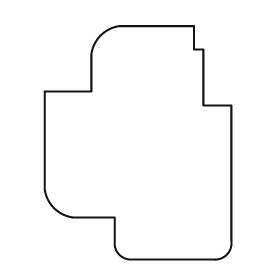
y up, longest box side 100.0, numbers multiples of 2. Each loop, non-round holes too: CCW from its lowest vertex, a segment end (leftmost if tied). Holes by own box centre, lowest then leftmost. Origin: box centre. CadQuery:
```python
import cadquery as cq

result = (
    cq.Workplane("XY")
    .moveTo(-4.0, -50.0)
    .lineTo(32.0, -50.0)
    .threePointArc((38.0, -48.0), (40.0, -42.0))
    .lineTo(40.0, 16.0)
    .lineTo(28.0, 16.0)
    .lineTo(28.0, 40.0)
    .lineTo(24.0, 40.0)
    .lineTo(24.0, 50.0)
    .lineTo(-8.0, 50.0)
    .threePointArc((-16.0, 46.0), (-20.0, 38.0))
    .lineTo(-20.0, 22.0)
    .lineTo(-40.0, 22.0)
    .lineTo(-40.0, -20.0)
    .threePointArc((-36.0, -28.0), (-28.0, -32.0))
    .lineTo(-10.0, -32.0)
    .lineTo(-10.0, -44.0)
    .threePointArc((-8.0, -48.0), (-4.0, -50.0))
    .close()
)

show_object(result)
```